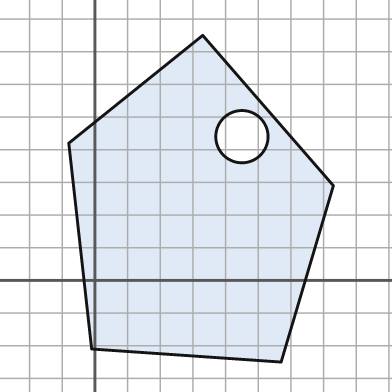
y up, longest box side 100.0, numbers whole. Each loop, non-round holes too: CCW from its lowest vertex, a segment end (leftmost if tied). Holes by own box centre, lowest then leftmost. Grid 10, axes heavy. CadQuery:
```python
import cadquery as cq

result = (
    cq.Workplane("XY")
    .moveTo(57.0, -25.0)
    .lineTo(73.0, 29.0)
    .lineTo(33.0, 75.0)
    .lineTo(-8.0, 42.0)
    .lineTo(-1.0, -21.0)
    .close()
    .moveTo(45.0, 44.0)
    .circle(8.0)
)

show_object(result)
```